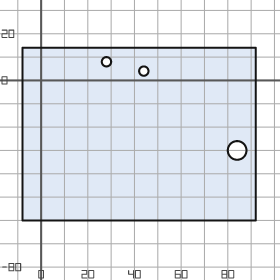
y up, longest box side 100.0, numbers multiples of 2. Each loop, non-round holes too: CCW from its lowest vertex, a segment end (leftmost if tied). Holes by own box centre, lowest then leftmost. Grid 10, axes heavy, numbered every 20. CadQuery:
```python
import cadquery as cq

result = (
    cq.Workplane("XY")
    .moveTo(-8.0, -60.0)
    .lineTo(92.0, -60.0)
    .lineTo(92.0, 14.0)
    .lineTo(-8.0, 14.0)
    .close()
    .moveTo(84.0, -30.0)
    .circle(4.0)
    .moveTo(44.0, 4.0)
    .circle(2.0)
    .moveTo(28.0, 8.0)
    .circle(2.0)
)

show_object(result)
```